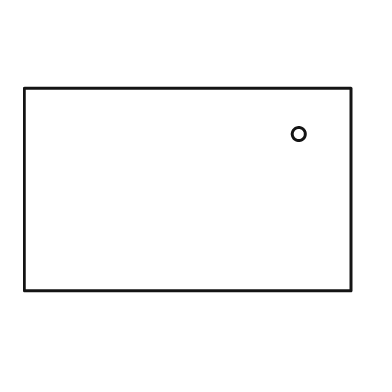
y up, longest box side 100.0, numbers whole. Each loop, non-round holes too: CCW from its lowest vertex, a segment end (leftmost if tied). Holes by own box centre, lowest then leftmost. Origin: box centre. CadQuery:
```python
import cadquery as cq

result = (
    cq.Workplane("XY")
    .moveTo(-50.0, -31.0)
    .lineTo(50.0, -31.0)
    .lineTo(50.0, 31.0)
    .lineTo(-50.0, 31.0)
    .close()
    .moveTo(34.0, 17.0)
    .circle(2.0)
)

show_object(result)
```